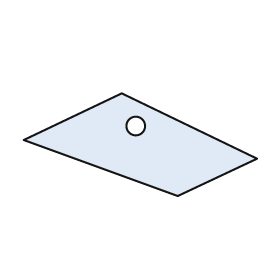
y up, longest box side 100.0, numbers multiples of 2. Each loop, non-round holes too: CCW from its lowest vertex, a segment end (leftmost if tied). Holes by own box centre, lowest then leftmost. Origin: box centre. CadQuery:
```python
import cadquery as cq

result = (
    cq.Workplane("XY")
    .moveTo(16.0, -22.0)
    .lineTo(50.0, -6.0)
    .lineTo(-8.0, 22.0)
    .lineTo(-50.0, 2.0)
    .close()
    .moveTo(-2.0, 8.0)
    .circle(4.0)
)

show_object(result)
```